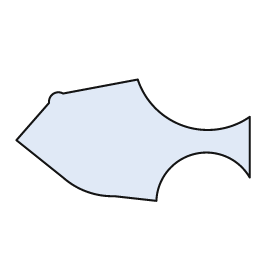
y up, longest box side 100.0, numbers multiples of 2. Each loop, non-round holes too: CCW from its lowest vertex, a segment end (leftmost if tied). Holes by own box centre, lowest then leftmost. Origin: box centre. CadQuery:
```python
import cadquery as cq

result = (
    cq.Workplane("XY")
    .moveTo(10.0, -26.0)
    .threePointArc((26.0, -6.0), (50.0, -16.0))
    .lineTo(50.0, 10.0)
    .threePointArc((22.0, 6.0), (2.0, 26.0))
    .lineTo(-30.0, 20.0)
    .threePointArc((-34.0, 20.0), (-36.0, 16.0))
    .lineTo(-50.0, 0.0)
    .lineTo(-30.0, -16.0)
    .threePointArc((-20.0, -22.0), (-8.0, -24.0))
    .close()
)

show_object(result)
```